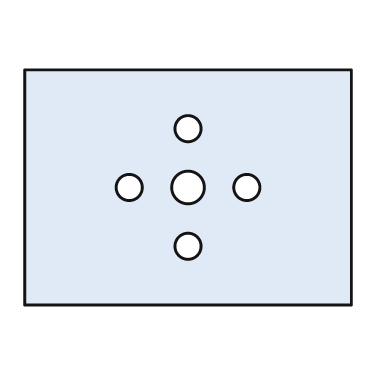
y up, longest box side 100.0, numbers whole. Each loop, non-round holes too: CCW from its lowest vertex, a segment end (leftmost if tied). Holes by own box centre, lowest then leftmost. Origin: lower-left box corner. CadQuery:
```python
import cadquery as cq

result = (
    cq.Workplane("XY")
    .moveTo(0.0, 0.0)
    .lineTo(100.0, 0.0)
    .lineTo(100.0, 72.0)
    .lineTo(0.0, 72.0)
    .close()
    .moveTo(50.0, 18.0)
    .circle(4.0)
    .moveTo(32.0, 36.0)
    .circle(4.0)
    .moveTo(50.0, 36.0)
    .circle(5.0)
    .moveTo(68.0, 36.0)
    .circle(4.0)
    .moveTo(50.0, 54.0)
    .circle(4.0)
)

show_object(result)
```